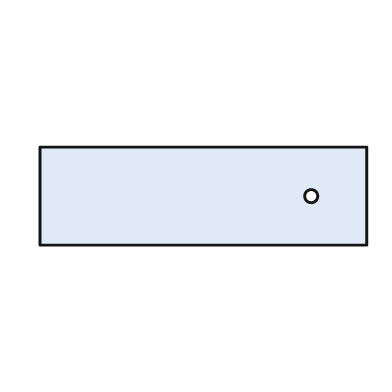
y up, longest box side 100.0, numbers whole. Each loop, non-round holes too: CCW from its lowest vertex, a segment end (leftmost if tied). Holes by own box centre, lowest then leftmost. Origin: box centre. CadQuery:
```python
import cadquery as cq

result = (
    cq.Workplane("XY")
    .moveTo(-50.0, -15.0)
    .lineTo(50.0, -15.0)
    .lineTo(50.0, 15.0)
    .lineTo(-50.0, 15.0)
    .close()
    .moveTo(33.0, 0.0)
    .circle(2.0)
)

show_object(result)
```